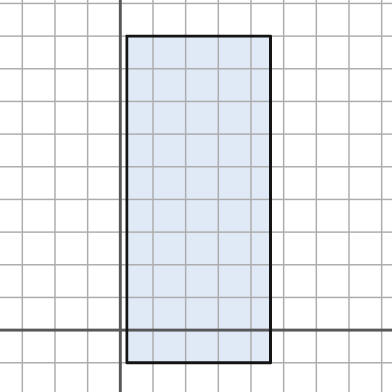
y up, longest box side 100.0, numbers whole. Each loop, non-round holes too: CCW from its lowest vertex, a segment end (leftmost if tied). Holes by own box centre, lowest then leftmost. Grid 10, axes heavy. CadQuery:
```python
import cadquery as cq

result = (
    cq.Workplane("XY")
    .moveTo(2.0, -10.0)
    .lineTo(46.0, -10.0)
    .lineTo(46.0, 90.0)
    .lineTo(2.0, 90.0)
    .close()
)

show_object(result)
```